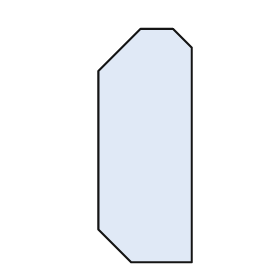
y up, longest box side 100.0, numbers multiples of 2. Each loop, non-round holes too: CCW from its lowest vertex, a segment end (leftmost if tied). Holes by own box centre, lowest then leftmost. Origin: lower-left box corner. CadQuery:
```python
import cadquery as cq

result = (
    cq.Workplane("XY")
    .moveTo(14.0, 0.0)
    .lineTo(40.0, 0.0)
    .lineTo(40.0, 92.0)
    .lineTo(32.0, 100.0)
    .lineTo(18.0, 100.0)
    .lineTo(0.0, 82.0)
    .lineTo(0.0, 14.0)
    .close()
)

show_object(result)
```